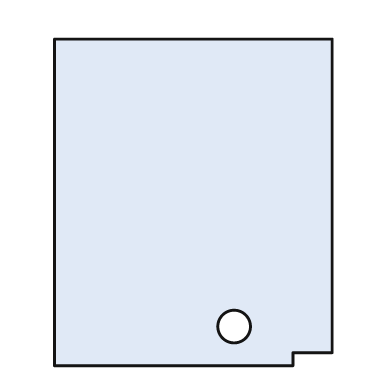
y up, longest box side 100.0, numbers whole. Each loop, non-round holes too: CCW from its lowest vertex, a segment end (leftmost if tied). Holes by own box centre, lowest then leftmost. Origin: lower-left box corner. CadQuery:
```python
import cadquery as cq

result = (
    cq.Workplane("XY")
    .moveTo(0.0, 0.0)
    .lineTo(73.0, 0.0)
    .lineTo(73.0, 4.0)
    .lineTo(85.0, 4.0)
    .lineTo(85.0, 100.0)
    .lineTo(0.0, 100.0)
    .close()
    .moveTo(55.0, 12.0)
    .circle(5.0)
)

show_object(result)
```